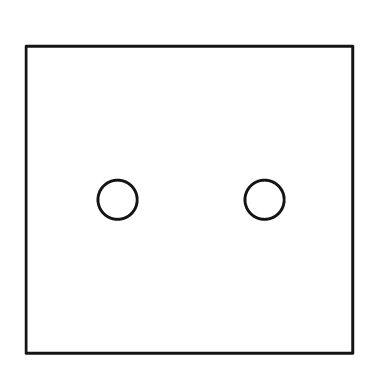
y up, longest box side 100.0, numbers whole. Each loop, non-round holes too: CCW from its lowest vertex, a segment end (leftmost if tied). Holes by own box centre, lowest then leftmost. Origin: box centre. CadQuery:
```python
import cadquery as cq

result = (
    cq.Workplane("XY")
    .moveTo(-50.0, -47.0)
    .lineTo(50.0, -47.0)
    .lineTo(50.0, 47.0)
    .lineTo(-50.0, 47.0)
    .close()
    .moveTo(-22.0, 0.0)
    .circle(6.0)
    .moveTo(23.0, 0.0)
    .circle(6.0)
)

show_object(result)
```